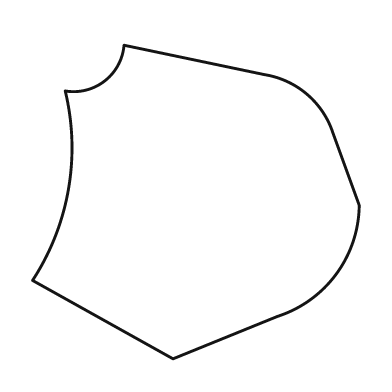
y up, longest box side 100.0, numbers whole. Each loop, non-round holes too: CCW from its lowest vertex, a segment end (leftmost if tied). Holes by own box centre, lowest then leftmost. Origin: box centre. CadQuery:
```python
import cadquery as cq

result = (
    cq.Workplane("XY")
    .moveTo(-7.0, -48.0)
    .lineTo(25.0, -35.0)
    .threePointArc((43.0, -22.0), (50.0, -1.0))
    .lineTo(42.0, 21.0)
    .threePointArc((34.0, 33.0), (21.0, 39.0))
    .lineTo(-22.0, 48.0)
    .threePointArc((-28.0, 37.0), (-40.0, 34.0))
    .threePointArc((-39.0, 4.0), (-50.0, -24.0))
    .close()
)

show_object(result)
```